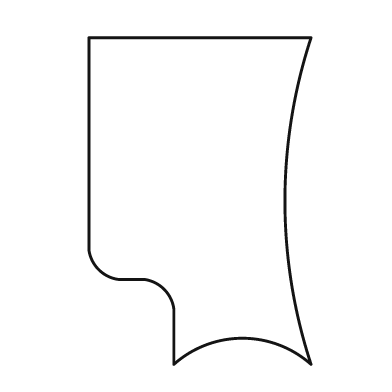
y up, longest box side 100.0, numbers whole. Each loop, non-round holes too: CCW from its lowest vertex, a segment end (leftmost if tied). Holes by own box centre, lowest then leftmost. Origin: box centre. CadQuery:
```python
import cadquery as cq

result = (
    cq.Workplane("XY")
    .moveTo(-8.0, -50.0)
    .threePointArc((13.0, -42.0), (34.0, -50.0))
    .threePointArc((26.0, 0.0), (34.0, 50.0))
    .lineTo(-34.0, 50.0)
    .lineTo(-34.0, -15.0)
    .threePointArc((-31.0, -21.0), (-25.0, -24.0))
    .lineTo(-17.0, -24.0)
    .threePointArc((-11.0, -27.0), (-8.0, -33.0))
    .close()
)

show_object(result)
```